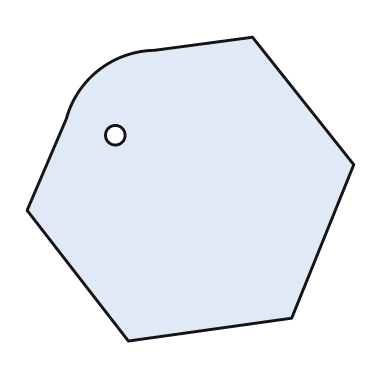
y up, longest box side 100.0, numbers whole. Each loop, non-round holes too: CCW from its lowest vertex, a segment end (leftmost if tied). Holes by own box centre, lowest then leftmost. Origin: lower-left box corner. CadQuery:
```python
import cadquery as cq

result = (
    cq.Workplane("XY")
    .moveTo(31.0, 0.0)
    .lineTo(81.0, 7.0)
    .lineTo(100.0, 54.0)
    .lineTo(69.0, 93.0)
    .lineTo(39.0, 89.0)
    .threePointArc((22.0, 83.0), (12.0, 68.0))
    .lineTo(0.0, 40.0)
    .close()
    .moveTo(27.0, 63.0)
    .circle(3.0)
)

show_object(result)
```